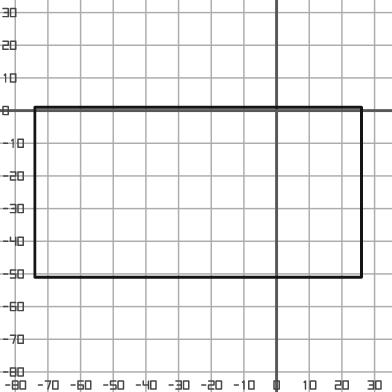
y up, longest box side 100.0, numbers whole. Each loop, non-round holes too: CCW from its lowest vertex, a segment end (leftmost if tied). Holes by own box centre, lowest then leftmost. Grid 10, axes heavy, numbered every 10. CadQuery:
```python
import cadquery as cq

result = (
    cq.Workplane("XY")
    .moveTo(-74.0, -51.0)
    .lineTo(26.0, -51.0)
    .lineTo(26.0, 1.0)
    .lineTo(-74.0, 1.0)
    .close()
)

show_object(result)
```